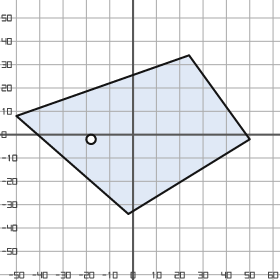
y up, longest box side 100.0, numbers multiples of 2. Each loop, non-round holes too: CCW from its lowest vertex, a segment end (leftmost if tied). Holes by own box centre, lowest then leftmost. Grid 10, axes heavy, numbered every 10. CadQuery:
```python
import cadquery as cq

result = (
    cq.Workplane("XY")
    .moveTo(-2.0, -34.0)
    .lineTo(50.0, -2.0)
    .lineTo(24.0, 34.0)
    .lineTo(-50.0, 8.0)
    .close()
    .moveTo(-18.0, -2.0)
    .circle(2.0)
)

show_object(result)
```